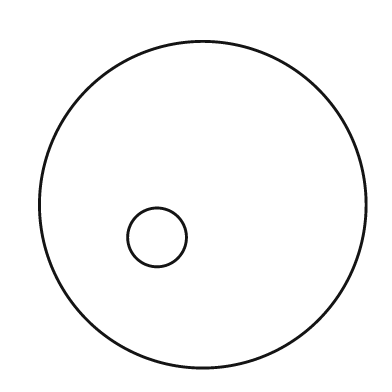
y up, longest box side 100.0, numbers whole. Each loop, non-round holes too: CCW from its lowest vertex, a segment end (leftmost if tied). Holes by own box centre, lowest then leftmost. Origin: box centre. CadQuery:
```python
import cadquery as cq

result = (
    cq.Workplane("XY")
    .moveTo(0.0, 0.0)
    .circle(50.0)
    .moveTo(-14.0, -10.0)
    .circle(9.0)
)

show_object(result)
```